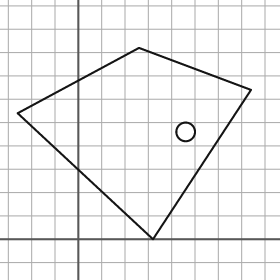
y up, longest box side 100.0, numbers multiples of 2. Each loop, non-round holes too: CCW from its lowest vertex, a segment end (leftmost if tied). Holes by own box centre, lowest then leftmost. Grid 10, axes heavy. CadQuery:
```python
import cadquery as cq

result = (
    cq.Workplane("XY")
    .moveTo(32.0, 0.0)
    .lineTo(74.0, 64.0)
    .lineTo(26.0, 82.0)
    .lineTo(-26.0, 54.0)
    .close()
    .moveTo(46.0, 46.0)
    .circle(4.0)
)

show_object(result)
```